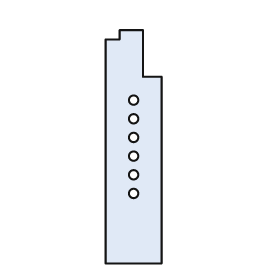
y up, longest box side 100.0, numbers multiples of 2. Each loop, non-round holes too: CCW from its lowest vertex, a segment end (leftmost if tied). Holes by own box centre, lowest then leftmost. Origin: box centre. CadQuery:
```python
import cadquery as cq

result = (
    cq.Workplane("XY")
    .moveTo(-12.0, -50.0)
    .lineTo(12.0, -50.0)
    .lineTo(12.0, 30.0)
    .lineTo(4.0, 30.0)
    .lineTo(4.0, 50.0)
    .lineTo(-6.0, 50.0)
    .lineTo(-6.0, 46.0)
    .lineTo(-12.0, 46.0)
    .close()
    .moveTo(0.0, -20.0)
    .circle(2.0)
    .moveTo(0.0, -12.0)
    .circle(2.0)
    .moveTo(0.0, -4.0)
    .circle(2.0)
    .moveTo(0.0, 4.0)
    .circle(2.0)
    .moveTo(0.0, 12.0)
    .circle(2.0)
    .moveTo(0.0, 20.0)
    .circle(2.0)
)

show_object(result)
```